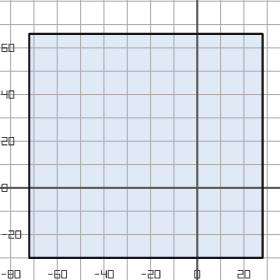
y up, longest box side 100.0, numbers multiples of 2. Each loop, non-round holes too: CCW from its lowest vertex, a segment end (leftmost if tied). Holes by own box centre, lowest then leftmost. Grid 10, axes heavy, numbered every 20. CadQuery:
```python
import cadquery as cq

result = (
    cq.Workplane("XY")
    .moveTo(-72.0, -30.0)
    .lineTo(28.0, -30.0)
    .lineTo(28.0, 66.0)
    .lineTo(-72.0, 66.0)
    .close()
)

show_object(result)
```